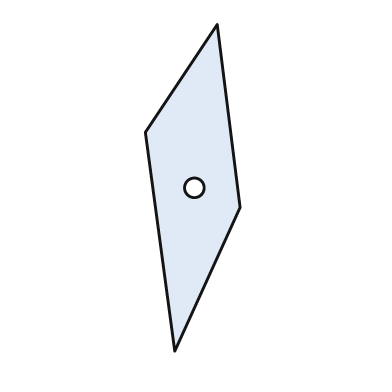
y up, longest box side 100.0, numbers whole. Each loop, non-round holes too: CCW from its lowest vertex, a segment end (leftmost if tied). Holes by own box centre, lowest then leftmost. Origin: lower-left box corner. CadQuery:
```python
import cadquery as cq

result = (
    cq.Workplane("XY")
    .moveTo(9.0, 0.0)
    .lineTo(29.0, 44.0)
    .lineTo(22.0, 100.0)
    .lineTo(0.0, 67.0)
    .close()
    .moveTo(15.0, 50.0)
    .circle(3.0)
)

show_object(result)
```